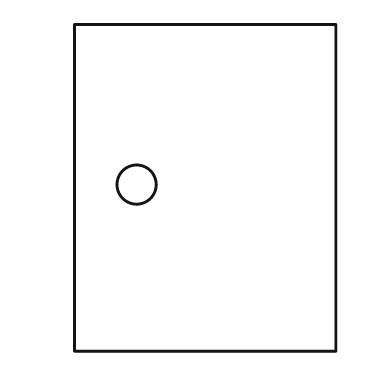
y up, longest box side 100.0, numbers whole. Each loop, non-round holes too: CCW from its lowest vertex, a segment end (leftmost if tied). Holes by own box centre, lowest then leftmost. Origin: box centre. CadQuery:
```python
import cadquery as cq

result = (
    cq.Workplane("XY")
    .moveTo(-40.0, -50.0)
    .lineTo(40.0, -50.0)
    .lineTo(40.0, 50.0)
    .lineTo(-40.0, 50.0)
    .close()
    .moveTo(-21.0, 1.0)
    .circle(6.0)
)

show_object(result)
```